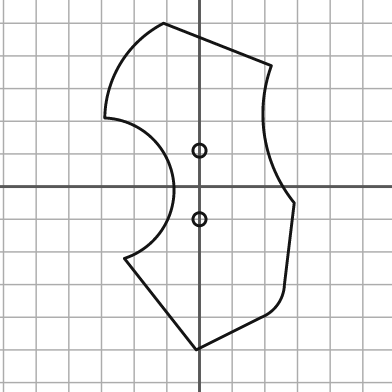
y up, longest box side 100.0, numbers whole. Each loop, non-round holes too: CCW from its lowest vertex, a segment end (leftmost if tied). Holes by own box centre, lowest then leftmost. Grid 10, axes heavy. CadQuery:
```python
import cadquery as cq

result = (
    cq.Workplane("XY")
    .moveTo(-1.0, -50.0)
    .lineTo(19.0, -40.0)
    .threePointArc((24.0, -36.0), (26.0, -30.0))
    .lineTo(29.0, -5.0)
    .threePointArc((20.0, 15.0), (22.0, 37.0))
    .lineTo(-11.0, 50.0)
    .threePointArc((-24.0, 38.0), (-29.0, 21.0))
    .threePointArc((-8.0, 2.0), (-23.0, -22.0))
    .close()
    .moveTo(0.0, -10.0)
    .circle(2.0)
    .moveTo(0.0, 11.0)
    .circle(2.0)
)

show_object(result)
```